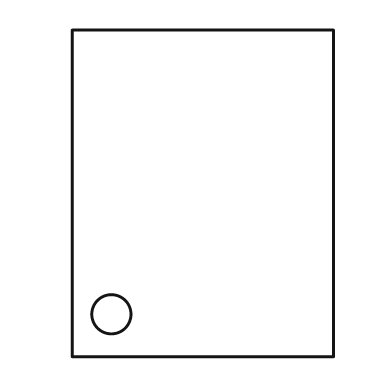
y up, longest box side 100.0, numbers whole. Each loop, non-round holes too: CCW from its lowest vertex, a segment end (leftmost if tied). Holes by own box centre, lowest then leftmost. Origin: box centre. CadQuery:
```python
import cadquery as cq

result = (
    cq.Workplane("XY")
    .moveTo(-40.0, -50.0)
    .lineTo(40.0, -50.0)
    .lineTo(40.0, 50.0)
    .lineTo(-40.0, 50.0)
    .close()
    .moveTo(-28.0, -37.0)
    .circle(6.0)
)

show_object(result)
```